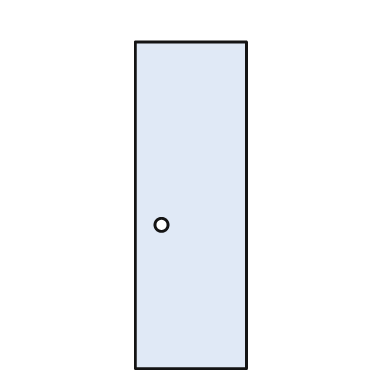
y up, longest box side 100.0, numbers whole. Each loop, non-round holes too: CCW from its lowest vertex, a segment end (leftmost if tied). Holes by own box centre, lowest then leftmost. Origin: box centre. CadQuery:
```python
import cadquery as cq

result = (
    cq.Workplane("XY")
    .moveTo(-17.0, -50.0)
    .lineTo(17.0, -50.0)
    .lineTo(17.0, 50.0)
    .lineTo(-17.0, 50.0)
    .close()
    .moveTo(-9.0, -6.0)
    .circle(2.0)
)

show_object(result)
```